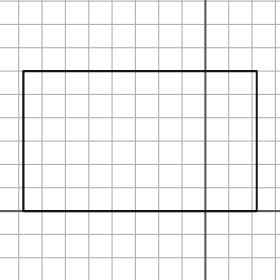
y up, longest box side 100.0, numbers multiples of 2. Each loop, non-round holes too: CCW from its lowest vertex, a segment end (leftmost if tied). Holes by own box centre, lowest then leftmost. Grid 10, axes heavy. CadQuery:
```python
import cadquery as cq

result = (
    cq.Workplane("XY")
    .moveTo(-78.0, 0.0)
    .lineTo(22.0, 0.0)
    .lineTo(22.0, 60.0)
    .lineTo(-78.0, 60.0)
    .close()
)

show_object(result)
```